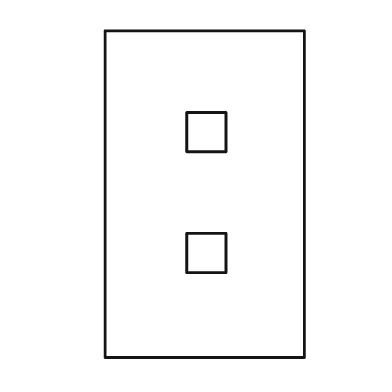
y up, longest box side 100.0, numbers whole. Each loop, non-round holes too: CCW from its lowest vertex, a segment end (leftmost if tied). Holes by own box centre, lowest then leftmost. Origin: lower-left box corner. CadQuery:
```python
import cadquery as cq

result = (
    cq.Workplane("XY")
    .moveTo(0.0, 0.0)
    .lineTo(61.0, 0.0)
    .lineTo(61.0, 100.0)
    .lineTo(0.0, 100.0)
    .close()
    .moveTo(25.0, 26.0)
    .lineTo(37.0, 26.0)
    .lineTo(37.0, 38.0)
    .lineTo(25.0, 38.0)
    .close()
    .moveTo(25.0, 63.0)
    .lineTo(37.0, 63.0)
    .lineTo(37.0, 75.0)
    .lineTo(25.0, 75.0)
    .close()
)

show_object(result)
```